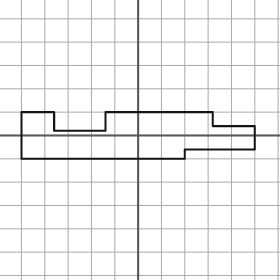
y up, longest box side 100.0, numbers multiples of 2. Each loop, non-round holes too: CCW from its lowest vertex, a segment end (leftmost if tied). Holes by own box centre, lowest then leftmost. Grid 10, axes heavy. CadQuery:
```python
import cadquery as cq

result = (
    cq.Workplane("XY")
    .moveTo(-50.0, -10.0)
    .lineTo(20.0, -10.0)
    .lineTo(20.0, -6.0)
    .lineTo(50.0, -6.0)
    .lineTo(50.0, 4.0)
    .lineTo(32.0, 4.0)
    .lineTo(32.0, 10.0)
    .lineTo(-14.0, 10.0)
    .lineTo(-14.0, 2.0)
    .lineTo(-36.0, 2.0)
    .lineTo(-36.0, 10.0)
    .lineTo(-50.0, 10.0)
    .close()
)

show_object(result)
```